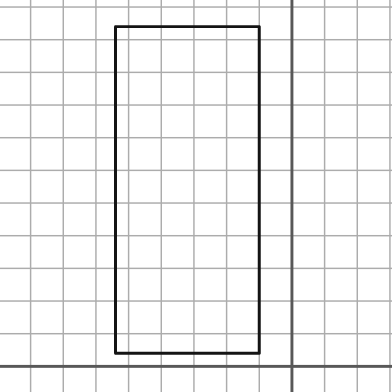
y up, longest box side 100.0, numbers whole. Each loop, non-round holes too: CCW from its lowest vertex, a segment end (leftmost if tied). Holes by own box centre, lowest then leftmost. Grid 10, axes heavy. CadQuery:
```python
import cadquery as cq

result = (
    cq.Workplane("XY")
    .moveTo(-54.0, 4.0)
    .lineTo(-10.0, 4.0)
    .lineTo(-10.0, 104.0)
    .lineTo(-54.0, 104.0)
    .close()
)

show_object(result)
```